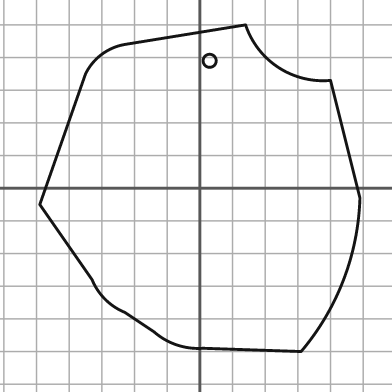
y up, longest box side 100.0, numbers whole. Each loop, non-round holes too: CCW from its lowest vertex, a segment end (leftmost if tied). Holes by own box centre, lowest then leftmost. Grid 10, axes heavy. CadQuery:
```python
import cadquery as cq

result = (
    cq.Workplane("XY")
    .moveTo(31.0, -50.0)
    .threePointArc((44.0, -28.0), (49.0, -3.0))
    .lineTo(40.0, 33.0)
    .threePointArc((24.0, 37.0), (14.0, 50.0))
    .lineTo(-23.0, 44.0)
    .threePointArc((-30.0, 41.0), (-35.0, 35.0))
    .lineTo(-49.0, -5.0)
    .lineTo(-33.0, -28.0)
    .threePointArc((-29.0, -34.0), (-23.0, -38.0))
    .lineTo(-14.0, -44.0)
    .threePointArc((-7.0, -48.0), (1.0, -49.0))
    .close()
    .moveTo(3.0, 39.0)
    .circle(2.0)
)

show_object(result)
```